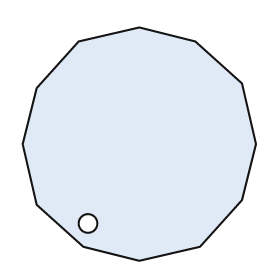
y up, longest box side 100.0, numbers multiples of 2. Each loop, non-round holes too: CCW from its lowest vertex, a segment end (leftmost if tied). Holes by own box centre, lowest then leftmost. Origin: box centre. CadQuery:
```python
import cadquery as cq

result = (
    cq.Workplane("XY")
    .moveTo(0.0, -50.0)
    .lineTo(26.0, -44.0)
    .lineTo(44.0, -24.0)
    .lineTo(50.0, 0.0)
    .lineTo(44.0, 26.0)
    .lineTo(24.0, 44.0)
    .lineTo(0.0, 50.0)
    .lineTo(-26.0, 44.0)
    .lineTo(-44.0, 24.0)
    .lineTo(-50.0, 0.0)
    .lineTo(-44.0, -26.0)
    .lineTo(-24.0, -44.0)
    .close()
    .moveTo(-22.0, -34.0)
    .circle(4.0)
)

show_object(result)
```